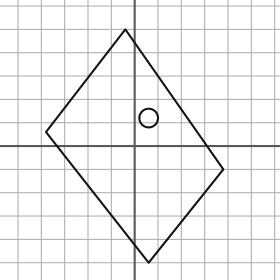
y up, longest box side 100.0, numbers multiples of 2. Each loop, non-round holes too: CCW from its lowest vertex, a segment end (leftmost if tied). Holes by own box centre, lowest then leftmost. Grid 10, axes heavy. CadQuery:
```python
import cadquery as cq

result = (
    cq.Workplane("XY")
    .moveTo(6.0, -50.0)
    .lineTo(38.0, -10.0)
    .lineTo(-4.0, 50.0)
    .lineTo(-38.0, 6.0)
    .close()
    .moveTo(6.0, 12.0)
    .circle(4.0)
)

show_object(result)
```